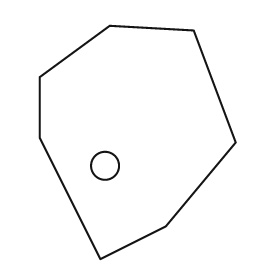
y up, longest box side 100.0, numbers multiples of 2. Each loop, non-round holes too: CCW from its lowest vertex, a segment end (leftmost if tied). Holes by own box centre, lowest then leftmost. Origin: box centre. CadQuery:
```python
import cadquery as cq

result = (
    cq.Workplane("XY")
    .moveTo(-16.0, -50.0)
    .lineTo(12.0, -36.0)
    .lineTo(42.0, 0.0)
    .lineTo(24.0, 48.0)
    .lineTo(-12.0, 50.0)
    .lineTo(-42.0, 28.0)
    .lineTo(-42.0, 2.0)
    .close()
    .moveTo(-14.0, -10.0)
    .circle(6.0)
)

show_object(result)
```